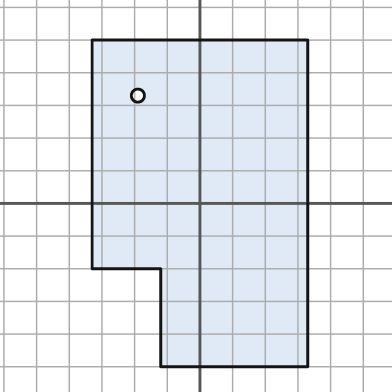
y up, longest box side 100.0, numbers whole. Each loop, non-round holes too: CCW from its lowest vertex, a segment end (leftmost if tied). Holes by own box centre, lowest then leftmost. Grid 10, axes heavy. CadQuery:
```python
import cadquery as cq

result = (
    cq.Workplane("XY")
    .moveTo(-12.0, -50.0)
    .lineTo(33.0, -50.0)
    .lineTo(33.0, 50.0)
    .lineTo(-33.0, 50.0)
    .lineTo(-33.0, -20.0)
    .lineTo(-12.0, -20.0)
    .close()
    .moveTo(-19.0, 33.0)
    .circle(2.0)
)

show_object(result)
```